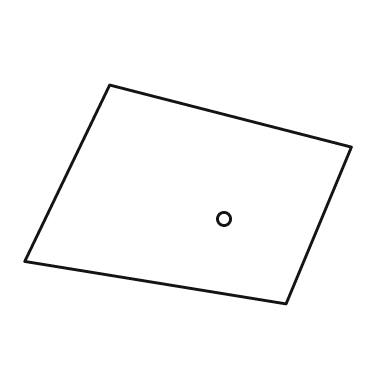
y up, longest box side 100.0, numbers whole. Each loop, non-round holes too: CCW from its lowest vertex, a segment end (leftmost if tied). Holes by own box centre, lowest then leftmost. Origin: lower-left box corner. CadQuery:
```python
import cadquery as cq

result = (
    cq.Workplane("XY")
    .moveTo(80.0, 0.0)
    .lineTo(100.0, 48.0)
    .lineTo(26.0, 67.0)
    .lineTo(0.0, 13.0)
    .close()
    .moveTo(61.0, 26.0)
    .circle(2.0)
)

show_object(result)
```